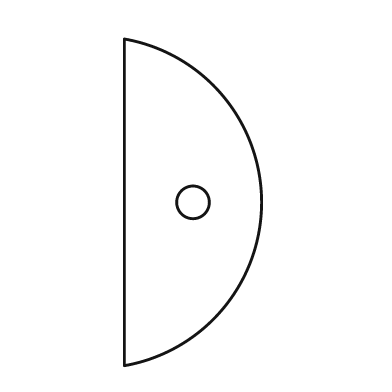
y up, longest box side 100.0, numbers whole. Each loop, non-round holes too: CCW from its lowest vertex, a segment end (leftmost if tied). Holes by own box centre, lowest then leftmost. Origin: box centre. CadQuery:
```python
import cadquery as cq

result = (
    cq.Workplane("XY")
    .moveTo(-21.0, -50.0)
    .threePointArc((21.0, 0.0), (-21.0, 50.0))
    .close()
    .moveTo(0.0, 0.0)
    .circle(5.0)
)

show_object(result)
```